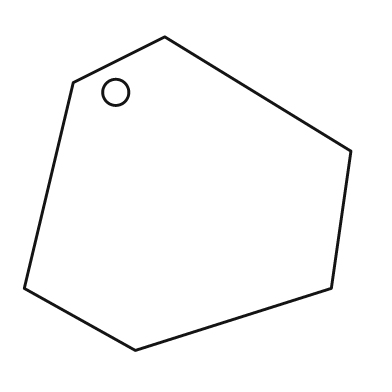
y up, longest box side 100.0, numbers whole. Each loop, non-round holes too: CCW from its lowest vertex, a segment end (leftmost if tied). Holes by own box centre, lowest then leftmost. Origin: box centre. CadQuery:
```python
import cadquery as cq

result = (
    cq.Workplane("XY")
    .moveTo(-16.0, -48.0)
    .lineTo(44.0, -29.0)
    .lineTo(50.0, 13.0)
    .lineTo(-7.0, 48.0)
    .lineTo(-35.0, 34.0)
    .lineTo(-50.0, -29.0)
    .close()
    .moveTo(-22.0, 31.0)
    .circle(4.0)
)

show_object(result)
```